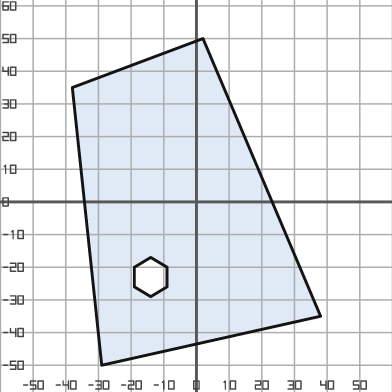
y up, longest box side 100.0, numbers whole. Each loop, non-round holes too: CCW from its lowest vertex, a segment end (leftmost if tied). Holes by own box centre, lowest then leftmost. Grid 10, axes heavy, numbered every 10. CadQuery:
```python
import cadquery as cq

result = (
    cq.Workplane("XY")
    .moveTo(-29.0, -50.0)
    .lineTo(38.0, -35.0)
    .lineTo(2.0, 50.0)
    .lineTo(-38.0, 35.0)
    .close()
    .moveTo(-14.0, -29.0)
    .lineTo(-9.0, -26.0)
    .lineTo(-9.0, -20.0)
    .lineTo(-14.0, -17.0)
    .lineTo(-19.0, -20.0)
    .lineTo(-19.0, -26.0)
    .close()
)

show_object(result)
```